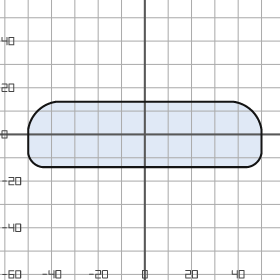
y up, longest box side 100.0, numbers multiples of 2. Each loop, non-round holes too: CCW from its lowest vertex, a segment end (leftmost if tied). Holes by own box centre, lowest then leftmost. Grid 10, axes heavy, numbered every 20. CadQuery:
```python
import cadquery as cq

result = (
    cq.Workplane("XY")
    .moveTo(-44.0, -14.0)
    .lineTo(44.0, -14.0)
    .threePointArc((48.0, -12.0), (50.0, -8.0))
    .lineTo(50.0, 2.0)
    .threePointArc((46.0, 10.0), (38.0, 14.0))
    .lineTo(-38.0, 14.0)
    .threePointArc((-46.0, 10.0), (-50.0, 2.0))
    .lineTo(-50.0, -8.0)
    .threePointArc((-48.0, -12.0), (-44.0, -14.0))
    .close()
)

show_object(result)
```